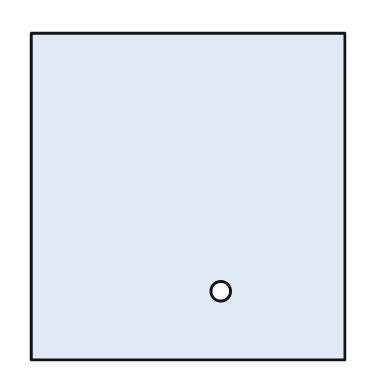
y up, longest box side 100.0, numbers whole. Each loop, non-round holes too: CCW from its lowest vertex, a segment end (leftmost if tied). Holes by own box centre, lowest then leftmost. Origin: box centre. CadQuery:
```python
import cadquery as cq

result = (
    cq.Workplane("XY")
    .moveTo(-48.0, -50.0)
    .lineTo(48.0, -50.0)
    .lineTo(48.0, 50.0)
    .lineTo(-48.0, 50.0)
    .close()
    .moveTo(10.0, -29.0)
    .circle(3.0)
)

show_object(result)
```